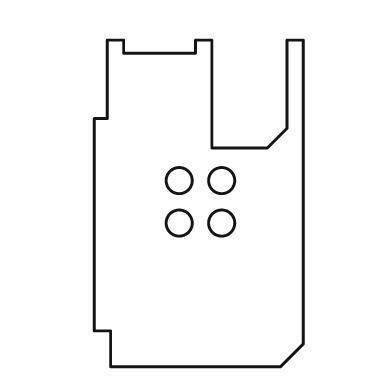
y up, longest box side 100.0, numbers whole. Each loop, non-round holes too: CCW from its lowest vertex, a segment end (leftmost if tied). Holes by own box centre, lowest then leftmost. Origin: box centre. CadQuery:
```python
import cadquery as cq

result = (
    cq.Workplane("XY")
    .moveTo(-27.0, -50.0)
    .lineTo(25.0, -50.0)
    .lineTo(32.0, -43.0)
    .lineTo(32.0, 50.0)
    .lineTo(27.0, 50.0)
    .lineTo(27.0, 23.0)
    .lineTo(21.0, 17.0)
    .lineTo(4.0, 17.0)
    .lineTo(4.0, 50.0)
    .lineTo(-1.0, 50.0)
    .lineTo(-1.0, 46.0)
    .lineTo(-23.0, 46.0)
    .lineTo(-23.0, 50.0)
    .lineTo(-28.0, 50.0)
    .lineTo(-28.0, 26.0)
    .lineTo(-32.0, 26.0)
    .lineTo(-32.0, -39.0)
    .lineTo(-27.0, -39.0)
    .close()
    .moveTo(-6.0, -6.0)
    .circle(4.0)
    .moveTo(7.0, -6.0)
    .circle(4.0)
    .moveTo(-6.0, 7.0)
    .circle(4.0)
    .moveTo(7.0, 7.0)
    .circle(4.0)
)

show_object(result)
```